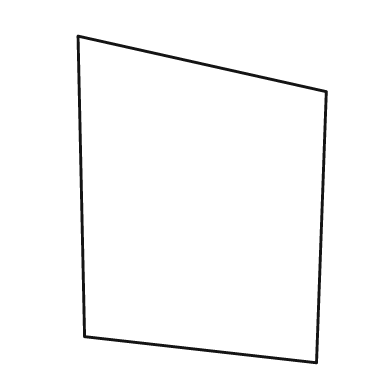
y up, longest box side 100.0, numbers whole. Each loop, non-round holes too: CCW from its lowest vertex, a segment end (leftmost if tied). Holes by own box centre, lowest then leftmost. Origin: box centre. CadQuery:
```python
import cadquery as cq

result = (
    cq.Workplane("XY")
    .moveTo(35.0, -50.0)
    .lineTo(38.0, 33.0)
    .lineTo(-38.0, 50.0)
    .lineTo(-36.0, -42.0)
    .close()
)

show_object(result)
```